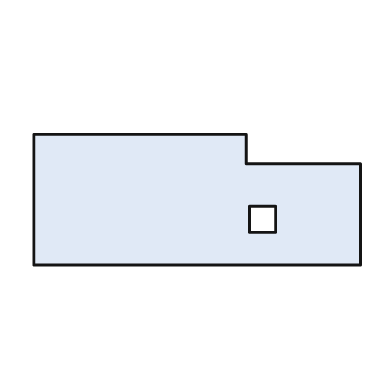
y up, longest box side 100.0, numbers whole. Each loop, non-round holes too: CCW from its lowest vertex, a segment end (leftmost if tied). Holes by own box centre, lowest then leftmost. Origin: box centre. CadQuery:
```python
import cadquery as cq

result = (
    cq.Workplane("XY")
    .moveTo(-50.0, -20.0)
    .lineTo(50.0, -20.0)
    .lineTo(50.0, 11.0)
    .lineTo(15.0, 11.0)
    .lineTo(15.0, 20.0)
    .lineTo(-50.0, 20.0)
    .close()
    .moveTo(16.0, -10.0)
    .lineTo(24.0, -10.0)
    .lineTo(24.0, -2.0)
    .lineTo(16.0, -2.0)
    .close()
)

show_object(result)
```